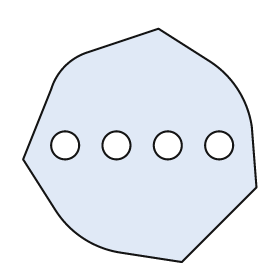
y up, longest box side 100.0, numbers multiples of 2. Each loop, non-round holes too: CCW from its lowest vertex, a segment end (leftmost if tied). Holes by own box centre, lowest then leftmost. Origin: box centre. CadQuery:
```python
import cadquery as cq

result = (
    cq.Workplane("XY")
    .moveTo(18.0, -50.0)
    .lineTo(50.0, -18.0)
    .lineTo(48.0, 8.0)
    .threePointArc((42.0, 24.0), (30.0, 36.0))
    .lineTo(8.0, 50.0)
    .lineTo(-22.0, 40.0)
    .threePointArc((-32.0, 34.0), (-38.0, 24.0))
    .lineTo(-50.0, -6.0)
    .lineTo(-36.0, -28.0)
    .threePointArc((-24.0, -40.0), (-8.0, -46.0))
    .close()
    .moveTo(-32.0, 0.0)
    .circle(6.0)
    .moveTo(-10.0, 0.0)
    .circle(6.0)
    .moveTo(12.0, 0.0)
    .circle(6.0)
    .moveTo(34.0, 0.0)
    .circle(6.0)
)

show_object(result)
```